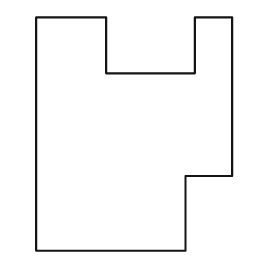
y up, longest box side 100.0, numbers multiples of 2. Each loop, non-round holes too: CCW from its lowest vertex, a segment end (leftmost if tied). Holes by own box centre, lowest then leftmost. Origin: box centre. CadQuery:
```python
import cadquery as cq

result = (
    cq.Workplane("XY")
    .moveTo(-42.0, -50.0)
    .lineTo(22.0, -50.0)
    .lineTo(22.0, -18.0)
    .lineTo(42.0, -18.0)
    .lineTo(42.0, 50.0)
    .lineTo(26.0, 50.0)
    .lineTo(26.0, 26.0)
    .lineTo(-12.0, 26.0)
    .lineTo(-12.0, 50.0)
    .lineTo(-42.0, 50.0)
    .close()
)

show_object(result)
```